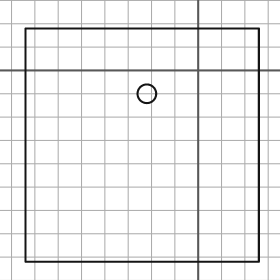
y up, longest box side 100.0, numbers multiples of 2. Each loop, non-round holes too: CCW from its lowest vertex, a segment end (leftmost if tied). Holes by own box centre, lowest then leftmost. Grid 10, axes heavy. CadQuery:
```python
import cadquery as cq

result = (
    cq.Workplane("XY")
    .moveTo(-74.0, -82.0)
    .lineTo(26.0, -82.0)
    .lineTo(26.0, 18.0)
    .lineTo(-74.0, 18.0)
    .close()
    .moveTo(-22.0, -10.0)
    .circle(4.0)
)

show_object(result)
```